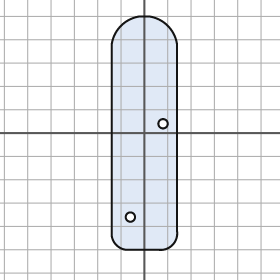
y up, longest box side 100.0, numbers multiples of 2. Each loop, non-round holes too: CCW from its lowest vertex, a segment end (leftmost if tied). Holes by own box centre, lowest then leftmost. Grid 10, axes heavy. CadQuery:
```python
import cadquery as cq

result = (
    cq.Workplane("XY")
    .moveTo(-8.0, -50.0)
    .lineTo(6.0, -50.0)
    .threePointArc((12.0, -48.0), (14.0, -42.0))
    .lineTo(14.0, 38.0)
    .threePointArc((10.0, 46.0), (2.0, 50.0))
    .lineTo(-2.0, 50.0)
    .threePointArc((-10.0, 46.0), (-14.0, 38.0))
    .lineTo(-14.0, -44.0)
    .threePointArc((-12.0, -48.0), (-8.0, -50.0))
    .close()
    .moveTo(-6.0, -36.0)
    .circle(2.0)
    .moveTo(8.0, 4.0)
    .circle(2.0)
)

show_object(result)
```